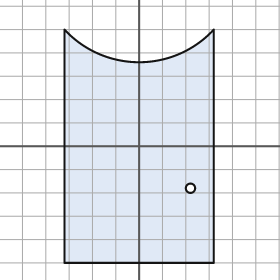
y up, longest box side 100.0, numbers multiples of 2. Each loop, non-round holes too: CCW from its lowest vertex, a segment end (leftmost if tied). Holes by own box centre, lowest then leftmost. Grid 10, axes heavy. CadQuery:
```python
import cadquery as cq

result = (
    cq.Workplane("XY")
    .moveTo(-32.0, -50.0)
    .lineTo(32.0, -50.0)
    .lineTo(32.0, 50.0)
    .threePointArc((0.0, 36.0), (-32.0, 50.0))
    .close()
    .moveTo(22.0, -18.0)
    .circle(2.0)
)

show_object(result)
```